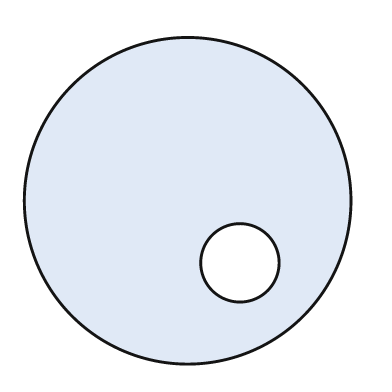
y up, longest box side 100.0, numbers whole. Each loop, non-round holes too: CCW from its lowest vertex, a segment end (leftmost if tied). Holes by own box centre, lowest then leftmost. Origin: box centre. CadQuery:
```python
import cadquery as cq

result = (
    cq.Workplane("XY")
    .moveTo(0.0, 0.0)
    .circle(50.0)
    .moveTo(16.0, -19.0)
    .circle(12.0)
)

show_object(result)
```